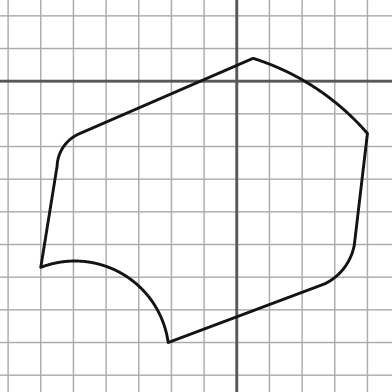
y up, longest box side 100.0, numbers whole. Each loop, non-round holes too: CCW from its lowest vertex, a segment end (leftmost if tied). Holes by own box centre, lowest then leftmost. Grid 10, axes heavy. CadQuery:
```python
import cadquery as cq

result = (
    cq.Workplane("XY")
    .moveTo(-21.0, -80.0)
    .lineTo(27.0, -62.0)
    .threePointArc((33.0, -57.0), (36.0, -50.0))
    .lineTo(40.0, -16.0)
    .threePointArc((24.0, -2.0), (5.0, 7.0))
    .lineTo(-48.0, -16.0)
    .threePointArc((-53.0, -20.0), (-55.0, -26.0))
    .lineTo(-60.0, -57.0)
    .threePointArc((-35.0, -59.0), (-21.0, -80.0))
    .close()
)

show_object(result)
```